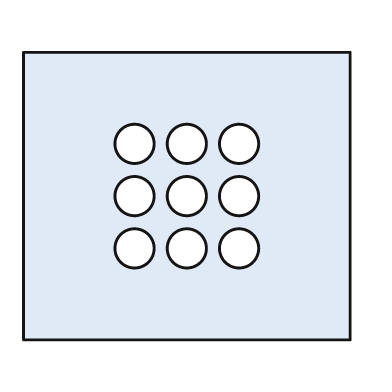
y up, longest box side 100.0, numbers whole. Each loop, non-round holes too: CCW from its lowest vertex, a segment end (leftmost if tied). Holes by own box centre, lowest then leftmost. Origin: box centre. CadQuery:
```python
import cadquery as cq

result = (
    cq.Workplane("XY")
    .moveTo(-50.0, -44.0)
    .lineTo(50.0, -44.0)
    .lineTo(50.0, 44.0)
    .lineTo(-50.0, 44.0)
    .close()
    .moveTo(-16.0, -16.0)
    .circle(6.0)
    .moveTo(0.0, -16.0)
    .circle(6.0)
    .moveTo(16.0, -16.0)
    .circle(6.0)
    .moveTo(-16.0, 0.0)
    .circle(6.0)
    .moveTo(0.0, 0.0)
    .circle(6.0)
    .moveTo(16.0, 0.0)
    .circle(6.0)
    .moveTo(-16.0, 16.0)
    .circle(6.0)
    .moveTo(0.0, 16.0)
    .circle(6.0)
    .moveTo(16.0, 16.0)
    .circle(6.0)
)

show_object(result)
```